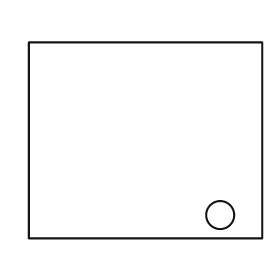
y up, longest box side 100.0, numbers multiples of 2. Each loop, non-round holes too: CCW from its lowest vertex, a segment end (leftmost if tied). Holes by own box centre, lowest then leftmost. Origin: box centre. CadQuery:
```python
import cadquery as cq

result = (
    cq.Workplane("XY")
    .moveTo(-50.0, -42.0)
    .lineTo(50.0, -42.0)
    .lineTo(50.0, 42.0)
    .lineTo(-50.0, 42.0)
    .close()
    .moveTo(32.0, -32.0)
    .circle(6.0)
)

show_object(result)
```